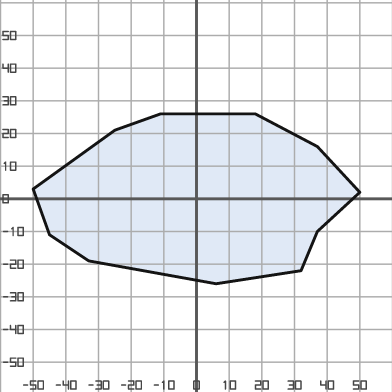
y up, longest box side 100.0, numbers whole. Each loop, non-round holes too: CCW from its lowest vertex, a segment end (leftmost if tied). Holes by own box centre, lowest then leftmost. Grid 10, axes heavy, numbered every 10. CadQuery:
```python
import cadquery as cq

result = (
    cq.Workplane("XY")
    .moveTo(6.0, -26.0)
    .lineTo(32.0, -22.0)
    .lineTo(37.0, -10.0)
    .lineTo(50.0, 2.0)
    .lineTo(37.0, 16.0)
    .lineTo(18.0, 26.0)
    .lineTo(-11.0, 26.0)
    .lineTo(-25.0, 21.0)
    .lineTo(-50.0, 3.0)
    .lineTo(-45.0, -11.0)
    .lineTo(-33.0, -19.0)
    .close()
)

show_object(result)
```